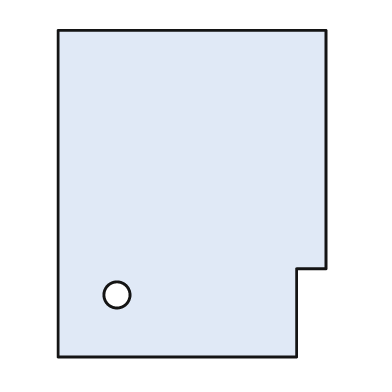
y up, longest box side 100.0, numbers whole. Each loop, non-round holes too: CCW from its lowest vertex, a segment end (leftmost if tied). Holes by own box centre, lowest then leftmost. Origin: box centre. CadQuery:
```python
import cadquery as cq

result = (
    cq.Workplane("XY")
    .moveTo(-41.0, -50.0)
    .lineTo(32.0, -50.0)
    .lineTo(32.0, -23.0)
    .lineTo(41.0, -23.0)
    .lineTo(41.0, 50.0)
    .lineTo(-41.0, 50.0)
    .close()
    .moveTo(-23.0, -31.0)
    .circle(4.0)
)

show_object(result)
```